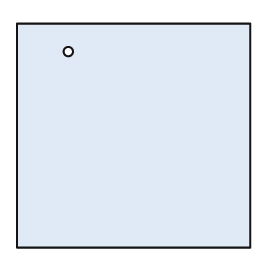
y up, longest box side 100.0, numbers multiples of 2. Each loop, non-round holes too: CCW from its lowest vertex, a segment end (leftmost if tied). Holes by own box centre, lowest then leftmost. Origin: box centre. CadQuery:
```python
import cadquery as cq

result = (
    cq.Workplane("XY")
    .moveTo(-50.0, -48.0)
    .lineTo(50.0, -48.0)
    .lineTo(50.0, 48.0)
    .lineTo(-50.0, 48.0)
    .close()
    .moveTo(-28.0, 36.0)
    .circle(2.0)
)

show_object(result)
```